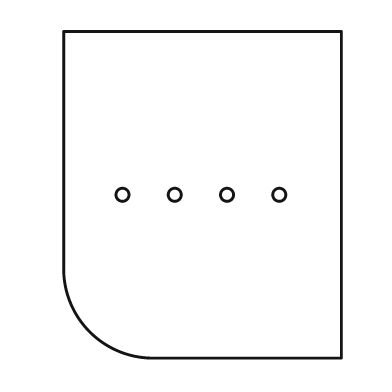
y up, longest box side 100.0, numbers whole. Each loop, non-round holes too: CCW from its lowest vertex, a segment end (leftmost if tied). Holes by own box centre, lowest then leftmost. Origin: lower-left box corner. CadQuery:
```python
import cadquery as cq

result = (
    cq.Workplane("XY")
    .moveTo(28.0, 0.0)
    .lineTo(85.0, 0.0)
    .lineTo(85.0, 100.0)
    .lineTo(0.0, 100.0)
    .lineTo(0.0, 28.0)
    .threePointArc((8.0, 8.0), (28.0, 0.0))
    .close()
    .moveTo(18.0, 50.0)
    .circle(2.0)
    .moveTo(34.0, 50.0)
    .circle(2.0)
    .moveTo(50.0, 50.0)
    .circle(2.0)
    .moveTo(66.0, 50.0)
    .circle(2.0)
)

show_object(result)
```